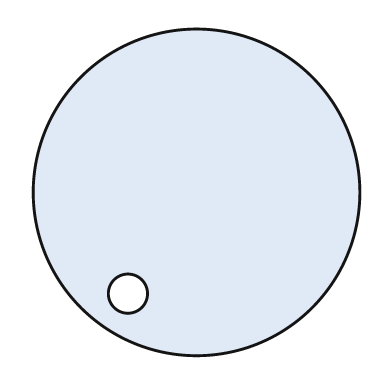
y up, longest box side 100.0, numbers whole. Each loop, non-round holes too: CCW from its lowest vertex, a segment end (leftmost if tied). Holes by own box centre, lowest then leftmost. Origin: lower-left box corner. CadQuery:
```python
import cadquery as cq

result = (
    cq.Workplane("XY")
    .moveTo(50.0, 50.0)
    .circle(50.0)
    .moveTo(29.0, 19.0)
    .circle(6.0)
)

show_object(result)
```